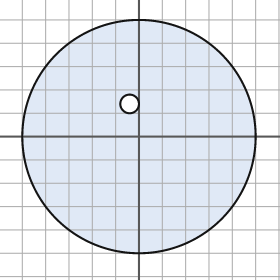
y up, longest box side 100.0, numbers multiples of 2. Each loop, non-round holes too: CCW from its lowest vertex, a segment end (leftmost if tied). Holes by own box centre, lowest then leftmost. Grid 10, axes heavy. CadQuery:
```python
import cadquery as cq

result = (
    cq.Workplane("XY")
    .moveTo(0.0, 0.0)
    .circle(50.0)
    .moveTo(-4.0, 14.0)
    .circle(4.0)
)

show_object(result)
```